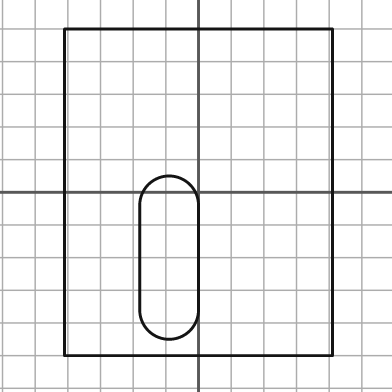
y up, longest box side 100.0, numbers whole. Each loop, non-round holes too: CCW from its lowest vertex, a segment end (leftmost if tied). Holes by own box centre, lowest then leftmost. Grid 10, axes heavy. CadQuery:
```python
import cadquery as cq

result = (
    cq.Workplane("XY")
    .moveTo(-41.0, -50.0)
    .lineTo(41.0, -50.0)
    .lineTo(41.0, 50.0)
    .lineTo(-41.0, 50.0)
    .close()
    .moveTo(-18.0, -36.0)
    .threePointArc((-9.0, -45.0), (0.0, -36.0))
    .lineTo(0.0, -4.0)
    .threePointArc((-9.0, 5.0), (-18.0, -4.0))
    .close()
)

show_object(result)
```